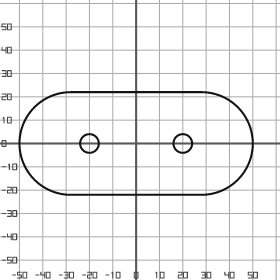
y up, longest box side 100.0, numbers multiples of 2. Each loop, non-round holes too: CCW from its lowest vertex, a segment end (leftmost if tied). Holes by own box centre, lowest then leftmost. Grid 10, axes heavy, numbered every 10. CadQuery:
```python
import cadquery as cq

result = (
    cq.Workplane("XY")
    .moveTo(-28.0, -22.0)
    .lineTo(28.0, -22.0)
    .threePointArc((50.0, 0.0), (28.0, 22.0))
    .lineTo(-28.0, 22.0)
    .threePointArc((-50.0, 0.0), (-28.0, -22.0))
    .close()
    .moveTo(-20.0, 0.0)
    .circle(4.0)
    .moveTo(20.0, 0.0)
    .circle(4.0)
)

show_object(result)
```